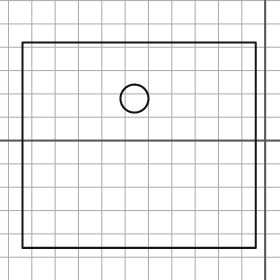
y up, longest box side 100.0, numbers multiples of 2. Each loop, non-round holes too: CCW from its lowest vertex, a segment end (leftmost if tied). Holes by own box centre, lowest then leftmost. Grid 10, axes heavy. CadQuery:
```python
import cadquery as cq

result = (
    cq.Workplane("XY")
    .moveTo(-104.0, -46.0)
    .lineTo(-4.0, -46.0)
    .lineTo(-4.0, 42.0)
    .lineTo(-104.0, 42.0)
    .close()
    .moveTo(-56.0, 18.0)
    .circle(6.0)
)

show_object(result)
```